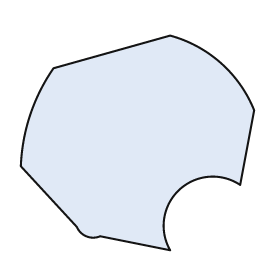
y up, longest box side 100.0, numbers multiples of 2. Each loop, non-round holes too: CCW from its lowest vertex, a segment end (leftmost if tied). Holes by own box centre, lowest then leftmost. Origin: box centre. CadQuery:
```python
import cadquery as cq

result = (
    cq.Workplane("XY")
    .moveTo(14.0, -46.0)
    .threePointArc((18.0, -20.0), (44.0, -18.0))
    .lineTo(50.0, 14.0)
    .threePointArc((36.0, 34.0), (14.0, 46.0))
    .lineTo(-36.0, 32.0)
    .threePointArc((-46.0, 12.0), (-50.0, -10.0))
    .lineTo(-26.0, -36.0)
    .threePointArc((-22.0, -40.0), (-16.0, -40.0))
    .close()
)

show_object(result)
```